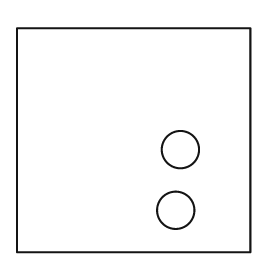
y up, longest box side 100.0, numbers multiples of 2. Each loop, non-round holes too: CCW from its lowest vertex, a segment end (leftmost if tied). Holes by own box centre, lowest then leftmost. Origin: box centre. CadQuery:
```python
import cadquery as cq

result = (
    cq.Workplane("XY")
    .moveTo(-50.0, -48.0)
    .lineTo(50.0, -48.0)
    .lineTo(50.0, 48.0)
    .lineTo(-50.0, 48.0)
    .close()
    .moveTo(18.0, -30.0)
    .circle(8.0)
    .moveTo(20.0, -4.0)
    .circle(8.0)
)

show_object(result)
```